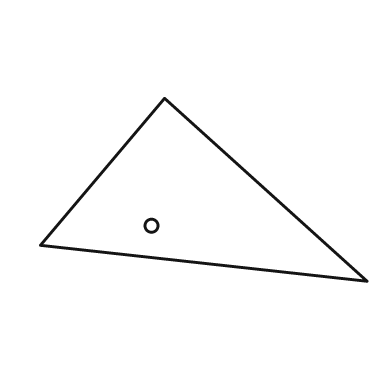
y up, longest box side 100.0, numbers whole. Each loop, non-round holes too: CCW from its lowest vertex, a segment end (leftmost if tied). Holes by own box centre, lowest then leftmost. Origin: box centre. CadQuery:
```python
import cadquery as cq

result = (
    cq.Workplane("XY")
    .moveTo(50.0, -28.0)
    .lineTo(-12.0, 28.0)
    .lineTo(-50.0, -17.0)
    .close()
    .moveTo(-16.0, -11.0)
    .circle(2.0)
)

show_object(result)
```